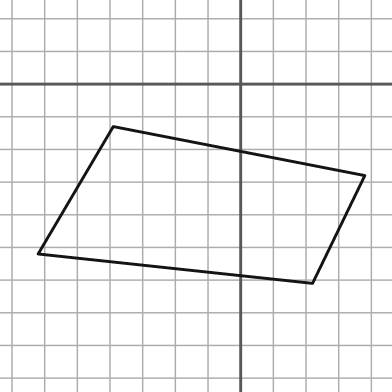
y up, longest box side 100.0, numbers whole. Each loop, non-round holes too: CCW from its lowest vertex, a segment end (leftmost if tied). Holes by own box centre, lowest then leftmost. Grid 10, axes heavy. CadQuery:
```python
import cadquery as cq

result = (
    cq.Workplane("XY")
    .moveTo(22.0, -61.0)
    .lineTo(38.0, -28.0)
    .lineTo(-39.0, -13.0)
    .lineTo(-62.0, -52.0)
    .close()
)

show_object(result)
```